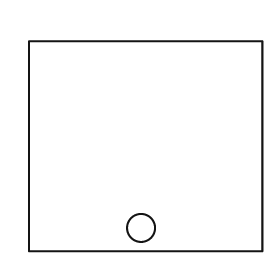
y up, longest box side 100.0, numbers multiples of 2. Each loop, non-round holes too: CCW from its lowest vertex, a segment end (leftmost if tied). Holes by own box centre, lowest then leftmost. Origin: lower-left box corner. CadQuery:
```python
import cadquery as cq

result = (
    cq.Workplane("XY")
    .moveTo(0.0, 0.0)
    .lineTo(100.0, 0.0)
    .lineTo(100.0, 90.0)
    .lineTo(0.0, 90.0)
    .close()
    .moveTo(48.0, 10.0)
    .circle(6.0)
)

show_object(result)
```